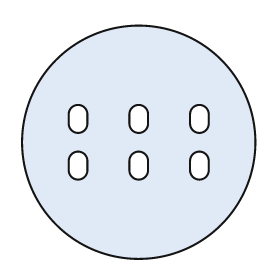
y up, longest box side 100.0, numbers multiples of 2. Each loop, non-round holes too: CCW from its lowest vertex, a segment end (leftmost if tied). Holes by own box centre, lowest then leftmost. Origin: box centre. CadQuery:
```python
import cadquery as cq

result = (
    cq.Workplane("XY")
    .moveTo(0.0, 0.0)
    .circle(50.0)
    .moveTo(-30.0, -12.0)
    .threePointArc((-26.0, -16.0), (-22.0, -12.0))
    .lineTo(-22.0, -8.0)
    .threePointArc((-26.0, -4.0), (-30.0, -8.0))
    .close()
    .moveTo(-4.0, -12.0)
    .threePointArc((0.0, -16.0), (4.0, -12.0))
    .lineTo(4.0, -8.0)
    .threePointArc((0.0, -4.0), (-4.0, -8.0))
    .close()
    .moveTo(22.0, -12.0)
    .threePointArc((26.0, -16.0), (30.0, -12.0))
    .lineTo(30.0, -8.0)
    .threePointArc((26.0, -4.0), (22.0, -8.0))
    .close()
    .moveTo(-30.0, 8.0)
    .threePointArc((-26.0, 4.0), (-22.0, 8.0))
    .lineTo(-22.0, 12.0)
    .threePointArc((-26.0, 16.0), (-30.0, 12.0))
    .close()
    .moveTo(-4.0, 8.0)
    .threePointArc((0.0, 4.0), (4.0, 8.0))
    .lineTo(4.0, 12.0)
    .threePointArc((0.0, 16.0), (-4.0, 12.0))
    .close()
    .moveTo(22.0, 8.0)
    .threePointArc((26.0, 4.0), (30.0, 8.0))
    .lineTo(30.0, 12.0)
    .threePointArc((26.0, 16.0), (22.0, 12.0))
    .close()
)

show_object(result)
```